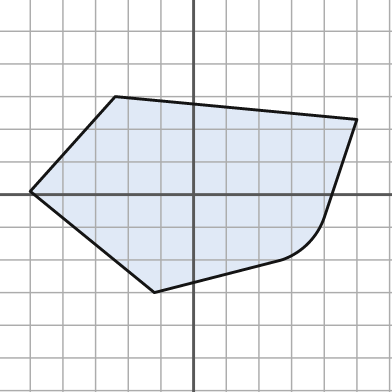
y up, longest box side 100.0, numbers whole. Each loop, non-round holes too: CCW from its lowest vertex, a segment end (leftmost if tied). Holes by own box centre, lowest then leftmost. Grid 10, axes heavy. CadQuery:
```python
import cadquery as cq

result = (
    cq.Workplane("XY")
    .moveTo(-12.0, -30.0)
    .lineTo(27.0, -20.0)
    .threePointArc((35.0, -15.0), (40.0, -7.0))
    .lineTo(50.0, 23.0)
    .lineTo(-24.0, 30.0)
    .lineTo(-50.0, 1.0)
    .close()
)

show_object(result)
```